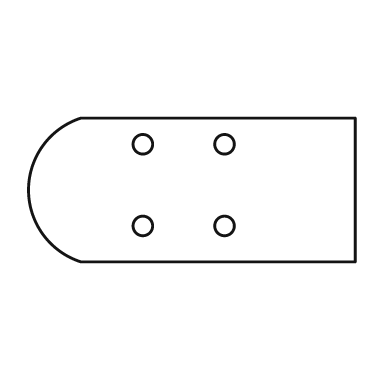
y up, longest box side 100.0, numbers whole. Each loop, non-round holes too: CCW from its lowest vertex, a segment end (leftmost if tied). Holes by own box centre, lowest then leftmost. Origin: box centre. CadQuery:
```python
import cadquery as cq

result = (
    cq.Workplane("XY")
    .moveTo(-34.0, -22.0)
    .lineTo(50.0, -22.0)
    .lineTo(50.0, 22.0)
    .lineTo(-34.0, 22.0)
    .threePointArc((-50.0, 0.0), (-34.0, -22.0))
    .close()
    .moveTo(-15.0, -11.0)
    .circle(3.0)
    .moveTo(10.0, -11.0)
    .circle(3.0)
    .moveTo(-15.0, 14.0)
    .circle(3.0)
    .moveTo(10.0, 14.0)
    .circle(3.0)
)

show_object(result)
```